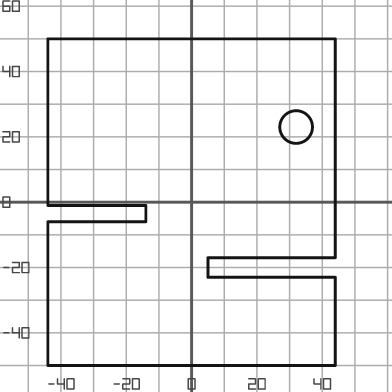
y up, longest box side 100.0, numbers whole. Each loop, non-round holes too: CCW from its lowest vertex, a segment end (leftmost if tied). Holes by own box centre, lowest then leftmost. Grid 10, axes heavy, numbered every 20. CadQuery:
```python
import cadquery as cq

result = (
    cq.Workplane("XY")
    .moveTo(-44.0, -50.0)
    .lineTo(44.0, -50.0)
    .lineTo(44.0, -23.0)
    .lineTo(5.0, -23.0)
    .lineTo(5.0, -17.0)
    .lineTo(44.0, -17.0)
    .lineTo(44.0, 50.0)
    .lineTo(-44.0, 50.0)
    .lineTo(-44.0, -1.0)
    .lineTo(-14.0, -1.0)
    .lineTo(-14.0, -6.0)
    .lineTo(-44.0, -6.0)
    .close()
    .moveTo(32.0, 23.0)
    .circle(5.0)
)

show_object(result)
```